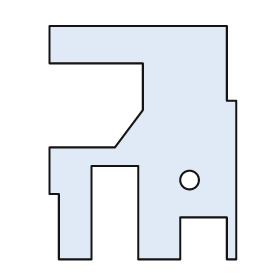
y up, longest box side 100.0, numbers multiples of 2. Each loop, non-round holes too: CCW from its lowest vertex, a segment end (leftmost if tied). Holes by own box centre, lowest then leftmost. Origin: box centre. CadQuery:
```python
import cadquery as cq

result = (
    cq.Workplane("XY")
    .moveTo(-36.0, -50.0)
    .lineTo(-22.0, -50.0)
    .lineTo(-22.0, -10.0)
    .lineTo(-2.0, -10.0)
    .lineTo(-2.0, -50.0)
    .lineTo(16.0, -50.0)
    .lineTo(16.0, -32.0)
    .lineTo(36.0, -32.0)
    .lineTo(36.0, -50.0)
    .lineTo(40.0, -50.0)
    .lineTo(40.0, 18.0)
    .lineTo(36.0, 18.0)
    .lineTo(36.0, 50.0)
    .lineTo(-40.0, 50.0)
    .lineTo(-40.0, 34.0)
    .lineTo(0.0, 34.0)
    .lineTo(0.0, 14.0)
    .lineTo(-12.0, -2.0)
    .lineTo(-40.0, -2.0)
    .lineTo(-40.0, -22.0)
    .lineTo(-36.0, -22.0)
    .close()
    .moveTo(20.0, -16.0)
    .circle(4.0)
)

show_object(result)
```